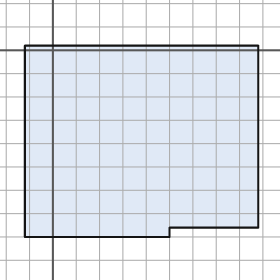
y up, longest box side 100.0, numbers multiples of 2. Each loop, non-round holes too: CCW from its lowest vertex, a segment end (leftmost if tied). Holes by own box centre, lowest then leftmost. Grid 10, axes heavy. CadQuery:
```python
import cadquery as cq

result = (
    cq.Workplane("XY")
    .moveTo(-12.0, -80.0)
    .lineTo(50.0, -80.0)
    .lineTo(50.0, -76.0)
    .lineTo(88.0, -76.0)
    .lineTo(88.0, 2.0)
    .lineTo(-12.0, 2.0)
    .close()
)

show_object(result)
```